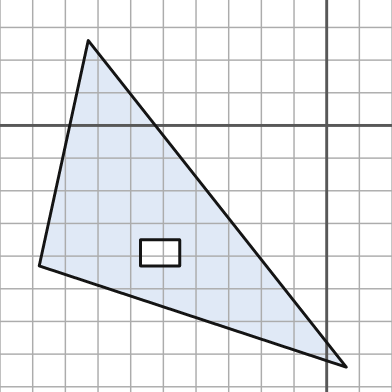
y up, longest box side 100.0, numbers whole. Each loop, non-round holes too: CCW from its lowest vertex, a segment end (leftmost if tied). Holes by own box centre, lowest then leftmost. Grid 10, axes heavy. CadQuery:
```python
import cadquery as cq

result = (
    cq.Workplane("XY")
    .moveTo(6.0, -74.0)
    .lineTo(-73.0, 26.0)
    .lineTo(-88.0, -43.0)
    .close()
    .moveTo(-57.0, -43.0)
    .lineTo(-45.0, -43.0)
    .lineTo(-45.0, -35.0)
    .lineTo(-57.0, -35.0)
    .close()
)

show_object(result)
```